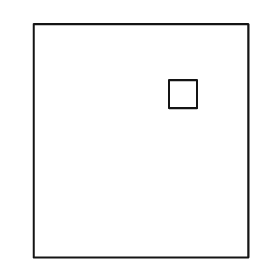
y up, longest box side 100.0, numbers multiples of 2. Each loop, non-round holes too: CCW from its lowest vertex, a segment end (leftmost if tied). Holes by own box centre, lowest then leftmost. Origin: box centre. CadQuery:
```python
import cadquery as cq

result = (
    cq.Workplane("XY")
    .moveTo(-46.0, -50.0)
    .lineTo(46.0, -50.0)
    .lineTo(46.0, 50.0)
    .lineTo(-46.0, 50.0)
    .close()
    .moveTo(12.0, 14.0)
    .lineTo(24.0, 14.0)
    .lineTo(24.0, 26.0)
    .lineTo(12.0, 26.0)
    .close()
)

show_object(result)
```